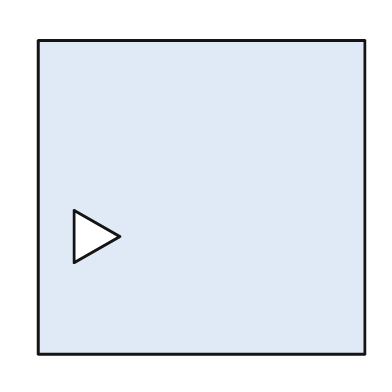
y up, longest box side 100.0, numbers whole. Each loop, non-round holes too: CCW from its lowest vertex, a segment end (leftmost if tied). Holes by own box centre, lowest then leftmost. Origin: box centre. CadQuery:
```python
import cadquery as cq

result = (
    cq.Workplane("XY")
    .moveTo(-50.0, -48.0)
    .lineTo(50.0, -48.0)
    .lineTo(50.0, 48.0)
    .lineTo(-50.0, 48.0)
    .close()
    .moveTo(-39.0, -20.0)
    .lineTo(-25.0, -12.0)
    .lineTo(-39.0, -4.0)
    .close()
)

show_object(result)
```